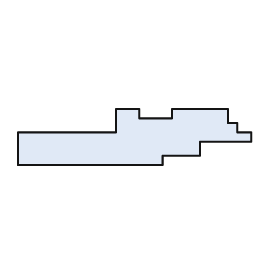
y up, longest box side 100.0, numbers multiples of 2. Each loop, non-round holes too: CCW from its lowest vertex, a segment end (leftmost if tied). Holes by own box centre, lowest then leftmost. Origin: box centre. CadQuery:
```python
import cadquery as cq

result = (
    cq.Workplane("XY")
    .moveTo(-50.0, -12.0)
    .lineTo(12.0, -12.0)
    .lineTo(12.0, -8.0)
    .lineTo(28.0, -8.0)
    .lineTo(28.0, -2.0)
    .lineTo(50.0, -2.0)
    .lineTo(50.0, 2.0)
    .lineTo(44.0, 2.0)
    .lineTo(44.0, 6.0)
    .lineTo(40.0, 6.0)
    .lineTo(40.0, 12.0)
    .lineTo(16.0, 12.0)
    .lineTo(16.0, 8.0)
    .lineTo(2.0, 8.0)
    .lineTo(2.0, 12.0)
    .lineTo(-8.0, 12.0)
    .lineTo(-8.0, 2.0)
    .lineTo(-50.0, 2.0)
    .close()
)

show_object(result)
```